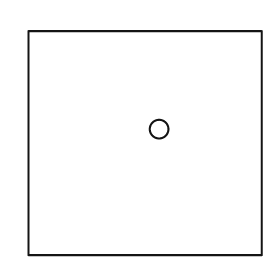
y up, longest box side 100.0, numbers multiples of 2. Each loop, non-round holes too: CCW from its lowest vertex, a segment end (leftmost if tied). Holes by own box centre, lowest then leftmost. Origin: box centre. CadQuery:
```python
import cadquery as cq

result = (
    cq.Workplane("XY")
    .moveTo(-50.0, -48.0)
    .lineTo(50.0, -48.0)
    .lineTo(50.0, 48.0)
    .lineTo(-50.0, 48.0)
    .close()
    .moveTo(6.0, 6.0)
    .circle(4.0)
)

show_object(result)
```